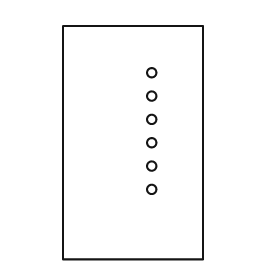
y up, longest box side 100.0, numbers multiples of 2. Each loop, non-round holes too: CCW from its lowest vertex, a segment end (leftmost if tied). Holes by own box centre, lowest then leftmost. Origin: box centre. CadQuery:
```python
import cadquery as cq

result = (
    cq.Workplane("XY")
    .moveTo(-30.0, -50.0)
    .lineTo(30.0, -50.0)
    .lineTo(30.0, 50.0)
    .lineTo(-30.0, 50.0)
    .close()
    .moveTo(8.0, -20.0)
    .circle(2.0)
    .moveTo(8.0, -10.0)
    .circle(2.0)
    .moveTo(8.0, 0.0)
    .circle(2.0)
    .moveTo(8.0, 10.0)
    .circle(2.0)
    .moveTo(8.0, 20.0)
    .circle(2.0)
    .moveTo(8.0, 30.0)
    .circle(2.0)
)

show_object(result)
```